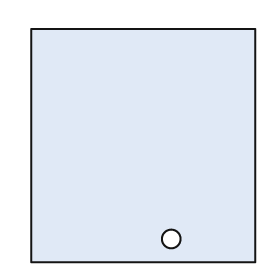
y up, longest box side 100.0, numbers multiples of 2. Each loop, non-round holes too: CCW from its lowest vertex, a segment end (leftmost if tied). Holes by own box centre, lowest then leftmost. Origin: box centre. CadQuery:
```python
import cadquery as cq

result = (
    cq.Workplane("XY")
    .moveTo(-48.0, -50.0)
    .lineTo(48.0, -50.0)
    .lineTo(48.0, 50.0)
    .lineTo(-48.0, 50.0)
    .close()
    .moveTo(12.0, -40.0)
    .circle(4.0)
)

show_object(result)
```